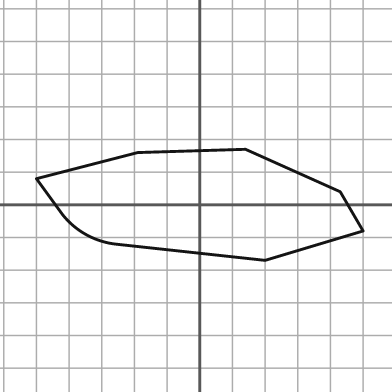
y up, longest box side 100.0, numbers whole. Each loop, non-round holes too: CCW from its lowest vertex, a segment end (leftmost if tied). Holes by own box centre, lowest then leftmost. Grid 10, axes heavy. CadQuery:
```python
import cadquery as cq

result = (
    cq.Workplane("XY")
    .moveTo(20.0, -17.0)
    .lineTo(50.0, -8.0)
    .lineTo(43.0, 4.0)
    .lineTo(14.0, 17.0)
    .lineTo(-19.0, 16.0)
    .lineTo(-50.0, 8.0)
    .lineTo(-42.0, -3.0)
    .threePointArc((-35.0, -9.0), (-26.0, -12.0))
    .close()
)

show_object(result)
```